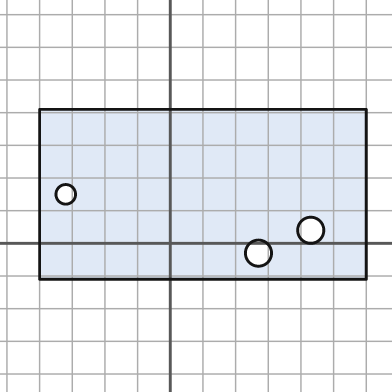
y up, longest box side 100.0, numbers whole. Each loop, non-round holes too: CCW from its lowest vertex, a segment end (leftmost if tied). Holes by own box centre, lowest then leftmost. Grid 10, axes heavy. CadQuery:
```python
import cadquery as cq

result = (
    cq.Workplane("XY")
    .moveTo(-40.0, -11.0)
    .lineTo(60.0, -11.0)
    .lineTo(60.0, 41.0)
    .lineTo(-40.0, 41.0)
    .close()
    .moveTo(27.0, -3.0)
    .circle(4.0)
    .moveTo(43.0, 4.0)
    .circle(4.0)
    .moveTo(-32.0, 15.0)
    .circle(3.0)
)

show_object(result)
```